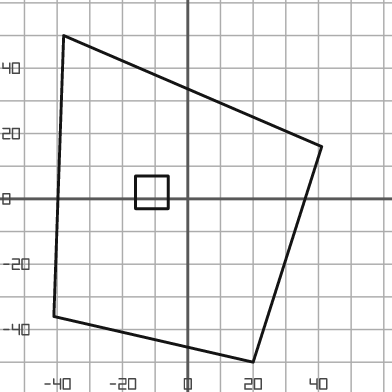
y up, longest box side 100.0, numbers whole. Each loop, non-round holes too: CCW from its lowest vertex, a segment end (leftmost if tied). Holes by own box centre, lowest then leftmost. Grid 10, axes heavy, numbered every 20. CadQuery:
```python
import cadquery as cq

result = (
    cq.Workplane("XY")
    .moveTo(20.0, -50.0)
    .lineTo(41.0, 16.0)
    .lineTo(-38.0, 50.0)
    .lineTo(-41.0, -36.0)
    .close()
    .moveTo(-16.0, -3.0)
    .lineTo(-6.0, -3.0)
    .lineTo(-6.0, 7.0)
    .lineTo(-16.0, 7.0)
    .close()
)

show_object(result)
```